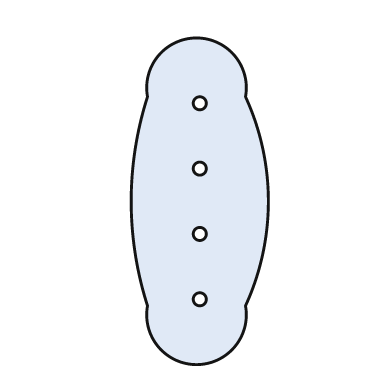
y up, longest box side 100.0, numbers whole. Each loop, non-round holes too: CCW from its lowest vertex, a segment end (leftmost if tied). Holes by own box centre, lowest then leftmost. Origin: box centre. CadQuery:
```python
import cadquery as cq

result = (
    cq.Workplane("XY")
    .moveTo(-16.0, -32.0)
    .threePointArc((-1.0, -50.0), (14.0, -32.0))
    .threePointArc((21.0, 0.0), (14.0, 32.0))
    .threePointArc((-1.0, 50.0), (-16.0, 32.0))
    .threePointArc((-21.0, 0.0), (-16.0, -32.0))
    .close()
    .moveTo(0.0, -30.0)
    .circle(2.0)
    .moveTo(0.0, -10.0)
    .circle(2.0)
    .moveTo(0.0, 10.0)
    .circle(2.0)
    .moveTo(0.0, 30.0)
    .circle(2.0)
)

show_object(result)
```